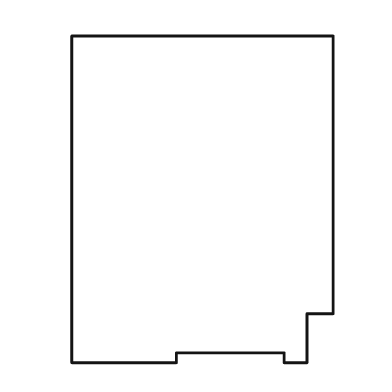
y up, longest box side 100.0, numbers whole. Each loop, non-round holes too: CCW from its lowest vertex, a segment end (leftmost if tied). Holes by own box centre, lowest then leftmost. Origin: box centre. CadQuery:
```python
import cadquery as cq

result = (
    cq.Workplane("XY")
    .moveTo(-40.0, -50.0)
    .lineTo(-8.0, -50.0)
    .lineTo(-8.0, -47.0)
    .lineTo(25.0, -47.0)
    .lineTo(25.0, -50.0)
    .lineTo(32.0, -50.0)
    .lineTo(32.0, -35.0)
    .lineTo(40.0, -35.0)
    .lineTo(40.0, 50.0)
    .lineTo(-40.0, 50.0)
    .close()
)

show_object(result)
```